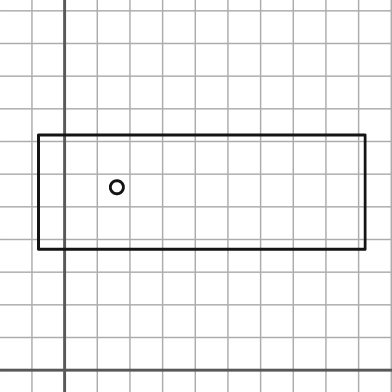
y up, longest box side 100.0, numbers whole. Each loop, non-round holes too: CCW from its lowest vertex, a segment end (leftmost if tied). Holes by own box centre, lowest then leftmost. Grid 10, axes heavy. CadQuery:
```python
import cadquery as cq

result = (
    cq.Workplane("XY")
    .moveTo(-8.0, 37.0)
    .lineTo(92.0, 37.0)
    .lineTo(92.0, 72.0)
    .lineTo(-8.0, 72.0)
    .close()
    .moveTo(16.0, 56.0)
    .circle(2.0)
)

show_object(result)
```